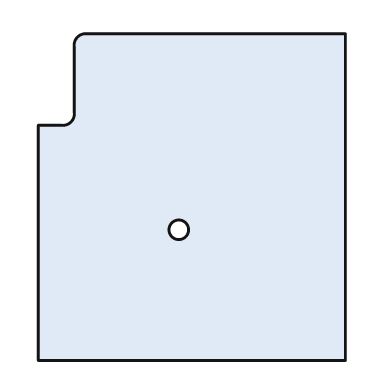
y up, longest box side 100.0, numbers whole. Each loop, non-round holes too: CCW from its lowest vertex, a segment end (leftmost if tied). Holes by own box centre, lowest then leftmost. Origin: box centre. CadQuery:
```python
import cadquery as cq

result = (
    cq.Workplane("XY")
    .moveTo(-47.0, -50.0)
    .lineTo(47.0, -50.0)
    .lineTo(47.0, 50.0)
    .lineTo(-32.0, 50.0)
    .threePointArc((-35.0, 49.0), (-36.0, 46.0))
    .lineTo(-36.0, 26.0)
    .threePointArc((-37.0, 23.0), (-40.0, 22.0))
    .lineTo(-47.0, 22.0)
    .close()
    .moveTo(-4.0, -10.0)
    .circle(3.0)
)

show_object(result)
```